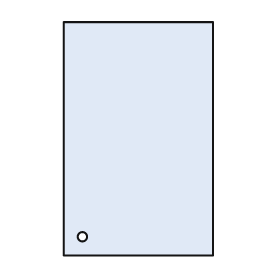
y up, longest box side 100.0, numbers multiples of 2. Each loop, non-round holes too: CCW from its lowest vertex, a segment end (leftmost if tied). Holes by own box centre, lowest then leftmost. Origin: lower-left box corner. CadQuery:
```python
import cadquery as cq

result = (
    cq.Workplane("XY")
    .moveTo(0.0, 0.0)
    .lineTo(64.0, 0.0)
    .lineTo(64.0, 100.0)
    .lineTo(0.0, 100.0)
    .close()
    .moveTo(8.0, 8.0)
    .circle(2.0)
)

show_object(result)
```